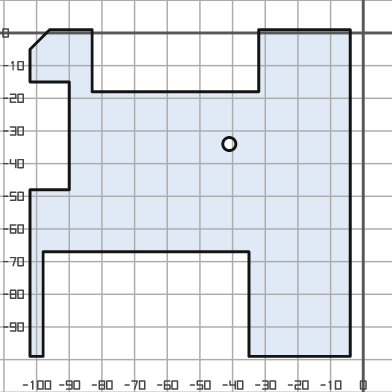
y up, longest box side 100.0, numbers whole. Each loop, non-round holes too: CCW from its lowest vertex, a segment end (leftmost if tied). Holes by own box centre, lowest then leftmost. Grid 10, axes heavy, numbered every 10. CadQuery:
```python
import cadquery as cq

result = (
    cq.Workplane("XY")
    .moveTo(-102.0, -99.0)
    .lineTo(-98.0, -99.0)
    .lineTo(-98.0, -67.0)
    .lineTo(-35.0, -67.0)
    .lineTo(-35.0, -99.0)
    .lineTo(-4.0, -99.0)
    .lineTo(-4.0, 1.0)
    .lineTo(-32.0, 1.0)
    .lineTo(-32.0, -18.0)
    .lineTo(-83.0, -18.0)
    .lineTo(-83.0, 1.0)
    .lineTo(-96.0, 1.0)
    .lineTo(-102.0, -5.0)
    .lineTo(-102.0, -15.0)
    .lineTo(-90.0, -15.0)
    .lineTo(-90.0, -48.0)
    .lineTo(-102.0, -48.0)
    .close()
    .moveTo(-41.0, -34.0)
    .circle(2.0)
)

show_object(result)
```